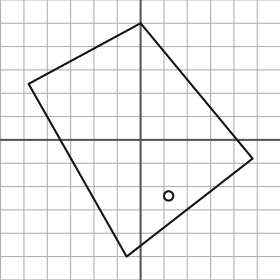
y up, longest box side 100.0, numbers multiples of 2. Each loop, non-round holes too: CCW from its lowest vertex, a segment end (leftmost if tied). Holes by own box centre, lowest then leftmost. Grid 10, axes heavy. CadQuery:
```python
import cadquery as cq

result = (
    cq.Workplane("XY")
    .moveTo(-6.0, -50.0)
    .lineTo(48.0, -8.0)
    .lineTo(0.0, 50.0)
    .lineTo(-48.0, 24.0)
    .close()
    .moveTo(12.0, -24.0)
    .circle(2.0)
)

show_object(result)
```